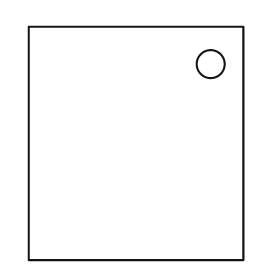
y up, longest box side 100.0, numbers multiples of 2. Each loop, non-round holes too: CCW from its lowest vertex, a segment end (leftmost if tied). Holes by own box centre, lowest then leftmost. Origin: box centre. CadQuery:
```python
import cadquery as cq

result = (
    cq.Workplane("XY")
    .moveTo(-46.0, -50.0)
    .lineTo(46.0, -50.0)
    .lineTo(46.0, 50.0)
    .lineTo(-46.0, 50.0)
    .close()
    .moveTo(32.0, 34.0)
    .circle(6.0)
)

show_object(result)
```